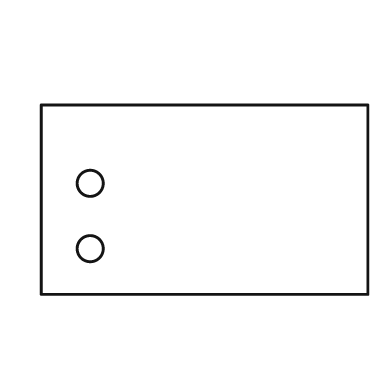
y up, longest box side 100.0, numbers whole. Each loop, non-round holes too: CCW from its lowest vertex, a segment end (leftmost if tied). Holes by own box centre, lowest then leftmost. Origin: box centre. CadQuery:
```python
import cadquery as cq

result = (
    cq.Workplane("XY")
    .moveTo(-50.0, -29.0)
    .lineTo(50.0, -29.0)
    .lineTo(50.0, 29.0)
    .lineTo(-50.0, 29.0)
    .close()
    .moveTo(-35.0, -15.0)
    .circle(4.0)
    .moveTo(-35.0, 5.0)
    .circle(4.0)
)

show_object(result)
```